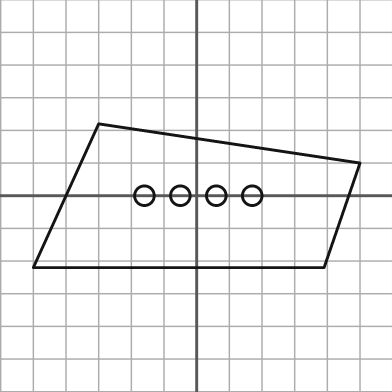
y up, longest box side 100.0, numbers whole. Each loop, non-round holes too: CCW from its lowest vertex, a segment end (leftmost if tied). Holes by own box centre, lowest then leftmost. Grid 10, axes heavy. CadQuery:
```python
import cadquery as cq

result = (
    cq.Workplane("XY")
    .moveTo(-50.0, -22.0)
    .lineTo(39.0, -22.0)
    .lineTo(50.0, 10.0)
    .lineTo(-30.0, 22.0)
    .close()
    .moveTo(-16.0, 0.0)
    .circle(3.0)
    .moveTo(-5.0, 0.0)
    .circle(3.0)
    .moveTo(6.0, 0.0)
    .circle(3.0)
    .moveTo(17.0, 0.0)
    .circle(3.0)
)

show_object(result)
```